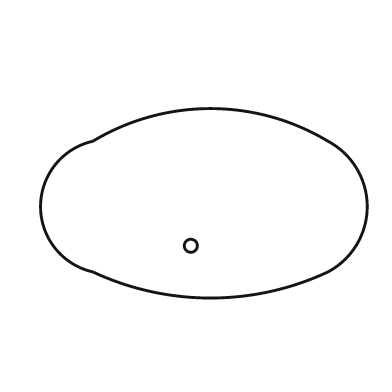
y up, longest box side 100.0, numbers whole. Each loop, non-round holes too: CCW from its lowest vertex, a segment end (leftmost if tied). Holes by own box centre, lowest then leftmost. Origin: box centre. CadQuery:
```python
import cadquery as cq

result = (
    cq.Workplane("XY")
    .moveTo(-34.0, -21.0)
    .threePointArc((2.0, -29.0), (38.0, -21.0))
    .threePointArc((50.0, -1.0), (38.0, 19.0))
    .threePointArc((2.0, 29.0), (-34.0, 19.0))
    .threePointArc((-50.0, -1.0), (-34.0, -21.0))
    .close()
    .moveTo(-4.0, -13.0)
    .circle(2.0)
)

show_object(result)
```